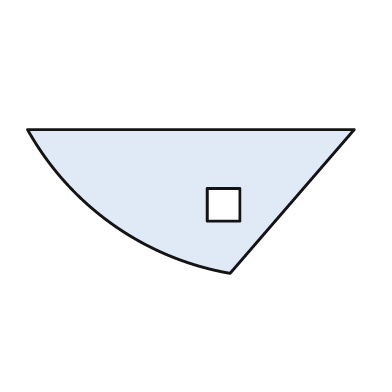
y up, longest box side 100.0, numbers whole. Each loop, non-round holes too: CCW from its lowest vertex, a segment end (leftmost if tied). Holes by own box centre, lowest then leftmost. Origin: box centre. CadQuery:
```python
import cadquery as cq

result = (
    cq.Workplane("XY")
    .moveTo(12.0, -22.0)
    .lineTo(50.0, 22.0)
    .lineTo(-50.0, 22.0)
    .threePointArc((-24.0, -7.0), (12.0, -22.0))
    .close()
    .moveTo(5.0, -6.0)
    .lineTo(15.0, -6.0)
    .lineTo(15.0, 4.0)
    .lineTo(5.0, 4.0)
    .close()
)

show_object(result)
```